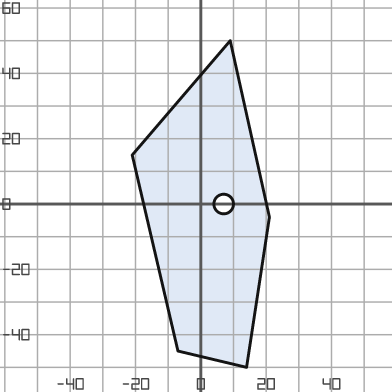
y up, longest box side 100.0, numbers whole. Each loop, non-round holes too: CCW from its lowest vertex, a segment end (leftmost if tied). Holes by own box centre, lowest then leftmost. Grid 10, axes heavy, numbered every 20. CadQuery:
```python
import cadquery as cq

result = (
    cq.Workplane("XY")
    .moveTo(14.0, -50.0)
    .lineTo(21.0, -4.0)
    .lineTo(9.0, 50.0)
    .lineTo(-21.0, 15.0)
    .lineTo(-7.0, -45.0)
    .close()
    .moveTo(7.0, 0.0)
    .circle(3.0)
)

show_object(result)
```